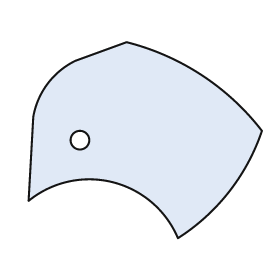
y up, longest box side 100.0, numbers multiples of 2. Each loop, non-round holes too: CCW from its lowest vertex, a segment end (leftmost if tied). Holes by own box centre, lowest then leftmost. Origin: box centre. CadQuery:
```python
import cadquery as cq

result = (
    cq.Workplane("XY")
    .moveTo(14.0, -42.0)
    .threePointArc((36.0, -22.0), (50.0, 4.0))
    .threePointArc((24.0, 28.0), (-8.0, 42.0))
    .lineTo(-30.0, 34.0)
    .threePointArc((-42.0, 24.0), (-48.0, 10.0))
    .lineTo(-50.0, -26.0)
    .threePointArc((-14.0, -18.0), (14.0, -42.0))
    .close()
    .moveTo(-28.0, 0.0)
    .circle(4.0)
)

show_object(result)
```